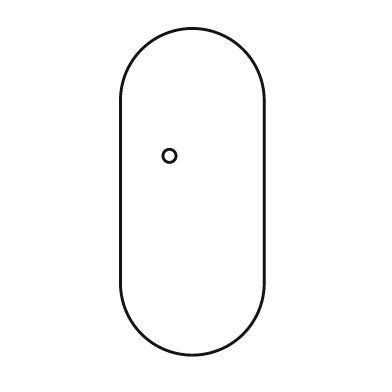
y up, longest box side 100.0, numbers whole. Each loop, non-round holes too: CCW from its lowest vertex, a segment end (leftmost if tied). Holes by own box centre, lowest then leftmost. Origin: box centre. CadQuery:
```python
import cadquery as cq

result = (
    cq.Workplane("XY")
    .moveTo(-22.0, -28.0)
    .threePointArc((0.0, -50.0), (22.0, -28.0))
    .lineTo(22.0, 28.0)
    .threePointArc((0.0, 50.0), (-22.0, 28.0))
    .close()
    .moveTo(-7.0, 11.0)
    .circle(2.0)
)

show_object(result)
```